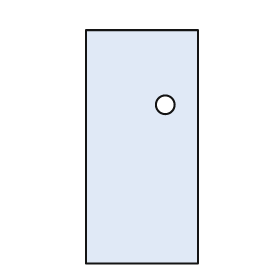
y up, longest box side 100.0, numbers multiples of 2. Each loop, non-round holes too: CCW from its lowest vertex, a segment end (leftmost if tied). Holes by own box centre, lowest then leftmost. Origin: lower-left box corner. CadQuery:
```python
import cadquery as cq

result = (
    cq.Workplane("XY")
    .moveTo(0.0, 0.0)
    .lineTo(48.0, 0.0)
    .lineTo(48.0, 100.0)
    .lineTo(0.0, 100.0)
    .close()
    .moveTo(34.0, 68.0)
    .circle(4.0)
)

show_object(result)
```